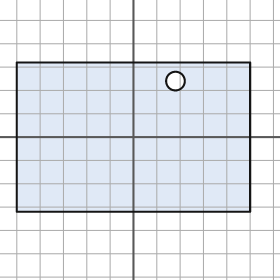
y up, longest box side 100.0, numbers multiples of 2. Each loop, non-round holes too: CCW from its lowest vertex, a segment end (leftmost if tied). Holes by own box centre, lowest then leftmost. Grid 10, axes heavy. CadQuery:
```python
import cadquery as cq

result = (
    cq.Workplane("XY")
    .moveTo(-50.0, -32.0)
    .lineTo(50.0, -32.0)
    .lineTo(50.0, 32.0)
    .lineTo(-50.0, 32.0)
    .close()
    .moveTo(18.0, 24.0)
    .circle(4.0)
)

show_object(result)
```